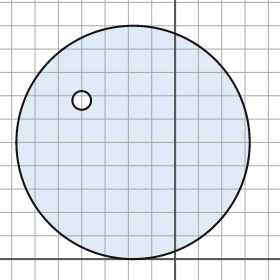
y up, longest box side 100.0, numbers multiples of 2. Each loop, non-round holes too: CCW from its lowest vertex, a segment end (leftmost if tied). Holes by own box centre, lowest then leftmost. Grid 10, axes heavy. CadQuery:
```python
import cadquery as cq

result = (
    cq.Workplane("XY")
    .moveTo(-18.0, 50.0)
    .circle(50.0)
    .moveTo(-40.0, 68.0)
    .circle(4.0)
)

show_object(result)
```